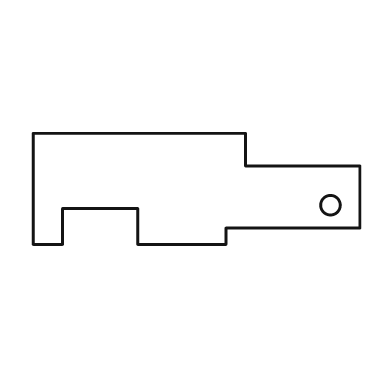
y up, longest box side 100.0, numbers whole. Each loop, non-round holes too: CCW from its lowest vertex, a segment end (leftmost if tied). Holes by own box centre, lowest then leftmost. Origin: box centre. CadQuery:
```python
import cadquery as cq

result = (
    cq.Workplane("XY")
    .moveTo(-50.0, -17.0)
    .lineTo(-41.0, -17.0)
    .lineTo(-41.0, -6.0)
    .lineTo(-18.0, -6.0)
    .lineTo(-18.0, -17.0)
    .lineTo(9.0, -17.0)
    .lineTo(9.0, -12.0)
    .lineTo(50.0, -12.0)
    .lineTo(50.0, 7.0)
    .lineTo(15.0, 7.0)
    .lineTo(15.0, 17.0)
    .lineTo(-50.0, 17.0)
    .close()
    .moveTo(41.0, -5.0)
    .circle(3.0)
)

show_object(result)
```